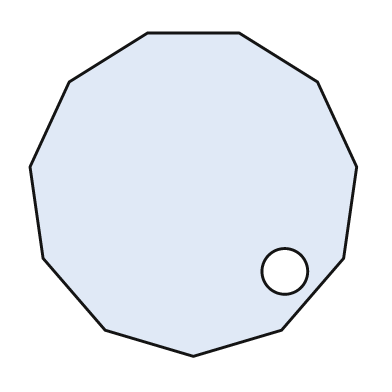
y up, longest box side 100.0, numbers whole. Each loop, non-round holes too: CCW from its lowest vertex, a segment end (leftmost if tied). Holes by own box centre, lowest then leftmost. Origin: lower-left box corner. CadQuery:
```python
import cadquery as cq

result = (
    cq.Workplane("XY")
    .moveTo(50.0, 0.0)
    .lineTo(77.0, 8.0)
    .lineTo(96.0, 30.0)
    .lineTo(100.0, 58.0)
    .lineTo(88.0, 84.0)
    .lineTo(64.0, 99.0)
    .lineTo(36.0, 99.0)
    .lineTo(12.0, 84.0)
    .lineTo(0.0, 58.0)
    .lineTo(4.0, 30.0)
    .lineTo(23.0, 8.0)
    .close()
    .moveTo(78.0, 26.0)
    .circle(7.0)
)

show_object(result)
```